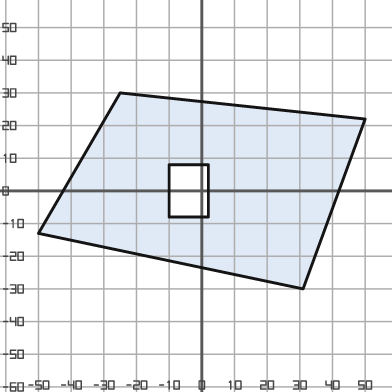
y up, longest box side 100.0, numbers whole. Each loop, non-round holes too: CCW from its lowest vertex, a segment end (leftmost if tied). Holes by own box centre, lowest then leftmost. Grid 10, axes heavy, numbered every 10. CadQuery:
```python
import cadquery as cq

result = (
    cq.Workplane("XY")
    .moveTo(31.0, -30.0)
    .lineTo(50.0, 22.0)
    .lineTo(-25.0, 30.0)
    .lineTo(-50.0, -13.0)
    .close()
    .moveTo(-10.0, -8.0)
    .lineTo(2.0, -8.0)
    .lineTo(2.0, 8.0)
    .lineTo(-10.0, 8.0)
    .close()
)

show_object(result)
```